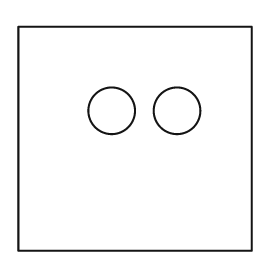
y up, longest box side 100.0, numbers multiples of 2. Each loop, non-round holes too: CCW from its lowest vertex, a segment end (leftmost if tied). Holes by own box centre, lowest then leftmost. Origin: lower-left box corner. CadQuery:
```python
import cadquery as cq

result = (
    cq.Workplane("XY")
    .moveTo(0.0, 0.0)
    .lineTo(100.0, 0.0)
    .lineTo(100.0, 96.0)
    .lineTo(0.0, 96.0)
    .close()
    .moveTo(40.0, 60.0)
    .circle(10.0)
    .moveTo(68.0, 60.0)
    .circle(10.0)
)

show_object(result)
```